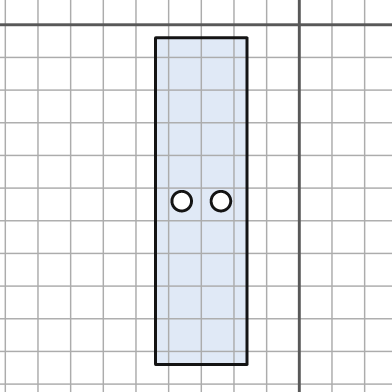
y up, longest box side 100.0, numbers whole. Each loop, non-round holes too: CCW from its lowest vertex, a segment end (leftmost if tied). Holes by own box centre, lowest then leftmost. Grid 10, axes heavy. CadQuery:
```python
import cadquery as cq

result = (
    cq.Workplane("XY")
    .moveTo(-44.0, -104.0)
    .lineTo(-16.0, -104.0)
    .lineTo(-16.0, -4.0)
    .lineTo(-44.0, -4.0)
    .close()
    .moveTo(-36.0, -54.0)
    .circle(3.0)
    .moveTo(-24.0, -54.0)
    .circle(3.0)
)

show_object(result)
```